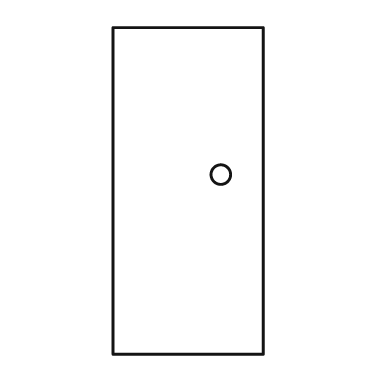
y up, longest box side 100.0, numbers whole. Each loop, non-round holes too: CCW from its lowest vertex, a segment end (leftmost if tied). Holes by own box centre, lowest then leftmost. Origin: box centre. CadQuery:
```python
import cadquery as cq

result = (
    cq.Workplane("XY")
    .moveTo(-23.0, -50.0)
    .lineTo(23.0, -50.0)
    .lineTo(23.0, 50.0)
    .lineTo(-23.0, 50.0)
    .close()
    .moveTo(10.0, 5.0)
    .circle(3.0)
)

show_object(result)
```